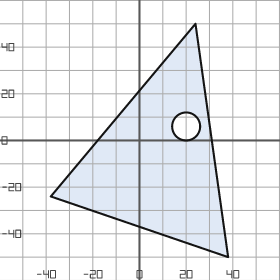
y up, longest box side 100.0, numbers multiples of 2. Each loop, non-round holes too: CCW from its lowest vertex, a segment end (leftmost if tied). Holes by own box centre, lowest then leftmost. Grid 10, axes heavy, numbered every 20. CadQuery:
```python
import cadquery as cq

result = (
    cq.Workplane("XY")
    .moveTo(38.0, -50.0)
    .lineTo(24.0, 50.0)
    .lineTo(-38.0, -24.0)
    .close()
    .moveTo(20.0, 6.0)
    .circle(6.0)
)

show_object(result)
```